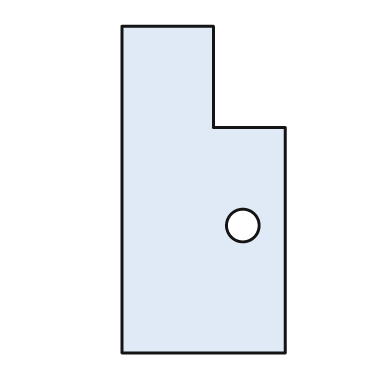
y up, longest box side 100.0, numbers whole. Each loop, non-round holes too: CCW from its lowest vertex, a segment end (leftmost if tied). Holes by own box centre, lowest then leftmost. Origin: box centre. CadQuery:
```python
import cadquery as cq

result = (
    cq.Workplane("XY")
    .moveTo(-25.0, -50.0)
    .lineTo(25.0, -50.0)
    .lineTo(25.0, 19.0)
    .lineTo(3.0, 19.0)
    .lineTo(3.0, 50.0)
    .lineTo(-25.0, 50.0)
    .close()
    .moveTo(12.0, -11.0)
    .circle(5.0)
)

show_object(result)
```